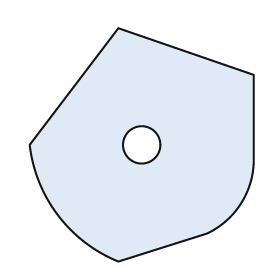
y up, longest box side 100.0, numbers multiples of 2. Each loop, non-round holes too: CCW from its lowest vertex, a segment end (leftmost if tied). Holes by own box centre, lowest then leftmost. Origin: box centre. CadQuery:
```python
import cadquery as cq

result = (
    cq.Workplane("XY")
    .moveTo(-10.0, -50.0)
    .lineTo(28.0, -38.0)
    .threePointArc((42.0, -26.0), (48.0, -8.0))
    .lineTo(48.0, 30.0)
    .lineTo(-10.0, 50.0)
    .lineTo(-48.0, 0.0)
    .threePointArc((-36.0, -30.0), (-10.0, -50.0))
    .close()
    .moveTo(0.0, 0.0)
    .circle(8.0)
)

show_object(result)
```